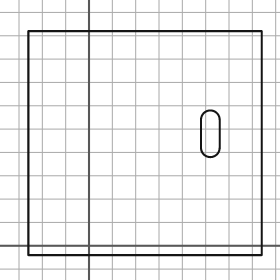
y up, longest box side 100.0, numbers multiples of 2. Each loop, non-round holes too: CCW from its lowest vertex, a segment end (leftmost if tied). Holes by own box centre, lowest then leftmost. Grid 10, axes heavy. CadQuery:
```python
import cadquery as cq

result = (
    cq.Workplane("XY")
    .moveTo(-26.0, -4.0)
    .lineTo(74.0, -4.0)
    .lineTo(74.0, 92.0)
    .lineTo(-26.0, 92.0)
    .close()
    .moveTo(48.0, 42.0)
    .threePointArc((52.0, 38.0), (56.0, 42.0))
    .lineTo(56.0, 54.0)
    .threePointArc((52.0, 58.0), (48.0, 54.0))
    .close()
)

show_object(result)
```